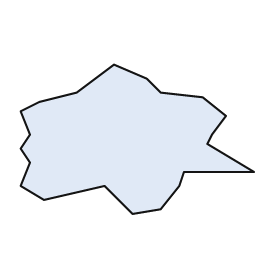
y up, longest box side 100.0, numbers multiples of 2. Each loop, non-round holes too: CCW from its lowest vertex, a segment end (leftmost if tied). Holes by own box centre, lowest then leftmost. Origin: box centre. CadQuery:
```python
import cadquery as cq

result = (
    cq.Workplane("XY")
    .moveTo(-2.0, -32.0)
    .lineTo(10.0, -30.0)
    .lineTo(18.0, -20.0)
    .lineTo(20.0, -14.0)
    .lineTo(50.0, -14.0)
    .lineTo(30.0, -2.0)
    .lineTo(32.0, 2.0)
    .lineTo(38.0, 10.0)
    .lineTo(28.0, 18.0)
    .lineTo(10.0, 20.0)
    .lineTo(4.0, 26.0)
    .lineTo(-10.0, 32.0)
    .lineTo(-26.0, 20.0)
    .lineTo(-42.0, 16.0)
    .lineTo(-50.0, 12.0)
    .lineTo(-46.0, 2.0)
    .lineTo(-50.0, -4.0)
    .lineTo(-46.0, -10.0)
    .lineTo(-50.0, -20.0)
    .lineTo(-40.0, -26.0)
    .lineTo(-14.0, -20.0)
    .close()
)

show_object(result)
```